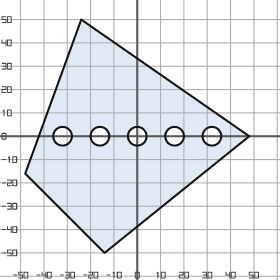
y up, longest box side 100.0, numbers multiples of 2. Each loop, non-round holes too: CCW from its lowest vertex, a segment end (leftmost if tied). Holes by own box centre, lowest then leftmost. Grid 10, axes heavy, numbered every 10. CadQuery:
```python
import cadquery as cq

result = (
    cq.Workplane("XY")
    .moveTo(-14.0, -50.0)
    .lineTo(48.0, 0.0)
    .lineTo(-24.0, 50.0)
    .lineTo(-48.0, -16.0)
    .close()
    .moveTo(-32.0, 0.0)
    .circle(4.0)
    .moveTo(-16.0, 0.0)
    .circle(4.0)
    .moveTo(0.0, 0.0)
    .circle(4.0)
    .moveTo(16.0, 0.0)
    .circle(4.0)
    .moveTo(32.0, 0.0)
    .circle(4.0)
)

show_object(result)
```